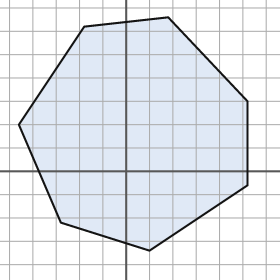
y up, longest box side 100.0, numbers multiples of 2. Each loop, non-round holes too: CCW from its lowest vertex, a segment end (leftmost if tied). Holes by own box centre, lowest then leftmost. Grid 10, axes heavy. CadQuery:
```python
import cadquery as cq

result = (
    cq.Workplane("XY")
    .moveTo(10.0, -34.0)
    .lineTo(52.0, -6.0)
    .lineTo(52.0, 30.0)
    .lineTo(18.0, 66.0)
    .lineTo(-18.0, 62.0)
    .lineTo(-46.0, 20.0)
    .lineTo(-28.0, -22.0)
    .close()
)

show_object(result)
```